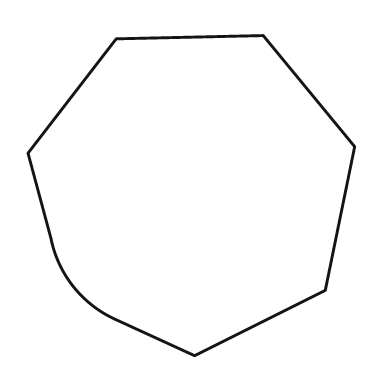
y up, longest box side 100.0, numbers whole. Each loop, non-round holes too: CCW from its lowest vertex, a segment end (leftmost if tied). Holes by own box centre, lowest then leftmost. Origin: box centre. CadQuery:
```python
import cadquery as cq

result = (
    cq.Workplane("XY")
    .moveTo(1.0, -49.0)
    .lineTo(41.0, -29.0)
    .lineTo(50.0, 15.0)
    .lineTo(22.0, 49.0)
    .lineTo(-23.0, 48.0)
    .lineTo(-50.0, 13.0)
    .lineTo(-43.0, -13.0)
    .threePointArc((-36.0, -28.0), (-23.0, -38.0))
    .close()
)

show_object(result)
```